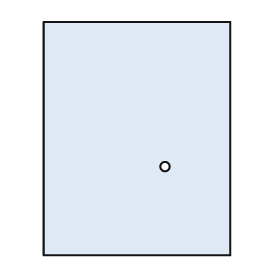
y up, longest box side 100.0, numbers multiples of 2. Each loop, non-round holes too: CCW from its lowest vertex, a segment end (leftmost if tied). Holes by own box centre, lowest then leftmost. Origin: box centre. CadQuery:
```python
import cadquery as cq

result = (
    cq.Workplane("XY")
    .moveTo(-40.0, -50.0)
    .lineTo(40.0, -50.0)
    .lineTo(40.0, 50.0)
    .lineTo(-40.0, 50.0)
    .close()
    .moveTo(12.0, -12.0)
    .circle(2.0)
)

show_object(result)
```